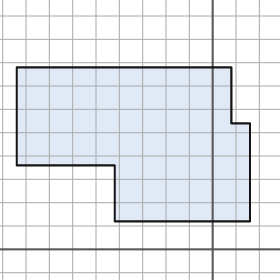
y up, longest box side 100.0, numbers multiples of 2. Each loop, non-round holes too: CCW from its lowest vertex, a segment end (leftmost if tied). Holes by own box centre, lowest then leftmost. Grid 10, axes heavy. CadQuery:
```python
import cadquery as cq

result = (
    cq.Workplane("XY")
    .moveTo(-42.0, 12.0)
    .lineTo(16.0, 12.0)
    .lineTo(16.0, 54.0)
    .lineTo(8.0, 54.0)
    .lineTo(8.0, 78.0)
    .lineTo(-84.0, 78.0)
    .lineTo(-84.0, 36.0)
    .lineTo(-42.0, 36.0)
    .close()
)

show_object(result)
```